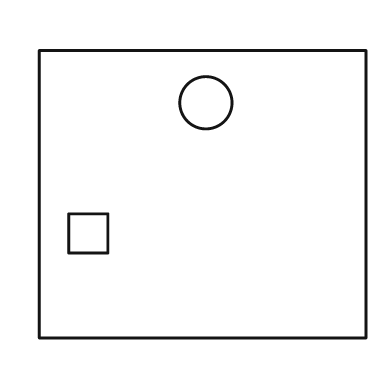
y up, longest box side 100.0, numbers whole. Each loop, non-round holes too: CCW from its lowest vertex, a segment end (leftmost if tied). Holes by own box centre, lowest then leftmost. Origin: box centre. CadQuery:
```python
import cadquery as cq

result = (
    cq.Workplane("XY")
    .moveTo(-50.0, -44.0)
    .lineTo(50.0, -44.0)
    .lineTo(50.0, 44.0)
    .lineTo(-50.0, 44.0)
    .close()
    .moveTo(-41.0, -18.0)
    .lineTo(-29.0, -18.0)
    .lineTo(-29.0, -6.0)
    .lineTo(-41.0, -6.0)
    .close()
    .moveTo(1.0, 28.0)
    .circle(8.0)
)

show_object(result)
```